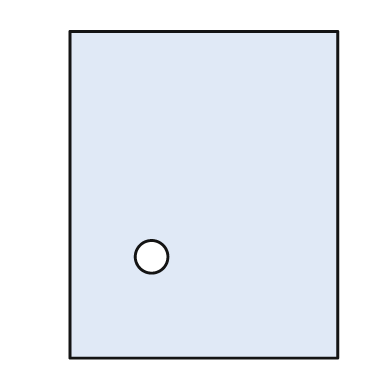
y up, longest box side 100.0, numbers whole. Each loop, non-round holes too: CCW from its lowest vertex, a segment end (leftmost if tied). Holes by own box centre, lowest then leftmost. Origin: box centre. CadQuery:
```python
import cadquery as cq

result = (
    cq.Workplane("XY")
    .moveTo(-41.0, -50.0)
    .lineTo(41.0, -50.0)
    .lineTo(41.0, 50.0)
    .lineTo(-41.0, 50.0)
    .close()
    .moveTo(-16.0, -19.0)
    .circle(5.0)
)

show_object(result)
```